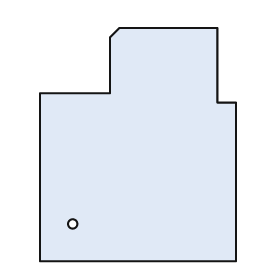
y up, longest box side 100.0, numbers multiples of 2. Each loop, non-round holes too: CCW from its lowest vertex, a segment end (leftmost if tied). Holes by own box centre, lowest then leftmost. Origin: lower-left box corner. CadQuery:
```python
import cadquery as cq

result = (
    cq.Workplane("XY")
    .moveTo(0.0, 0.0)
    .lineTo(84.0, 0.0)
    .lineTo(84.0, 68.0)
    .lineTo(76.0, 68.0)
    .lineTo(76.0, 100.0)
    .lineTo(34.0, 100.0)
    .lineTo(30.0, 96.0)
    .lineTo(30.0, 72.0)
    .lineTo(0.0, 72.0)
    .close()
    .moveTo(14.0, 16.0)
    .circle(2.0)
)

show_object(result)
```